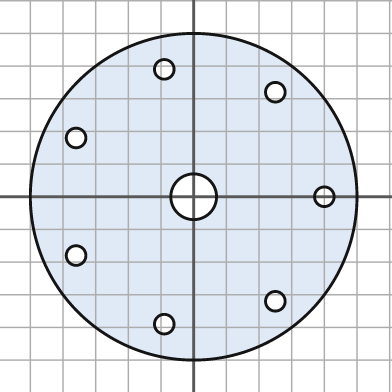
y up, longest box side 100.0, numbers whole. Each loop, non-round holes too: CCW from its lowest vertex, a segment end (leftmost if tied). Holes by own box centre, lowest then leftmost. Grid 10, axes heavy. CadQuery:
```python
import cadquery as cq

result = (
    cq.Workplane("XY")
    .moveTo(0.0, 0.0)
    .circle(50.0)
    .moveTo(-9.0, -39.0)
    .circle(3.0)
    .moveTo(25.0, -32.0)
    .circle(3.0)
    .moveTo(-36.0, -18.0)
    .circle(3.0)
    .moveTo(0.0, 0.0)
    .circle(7.0)
    .moveTo(40.0, 0.0)
    .circle(3.0)
    .moveTo(-36.0, 18.0)
    .circle(3.0)
    .moveTo(25.0, 32.0)
    .circle(3.0)
    .moveTo(-9.0, 39.0)
    .circle(3.0)
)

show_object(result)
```